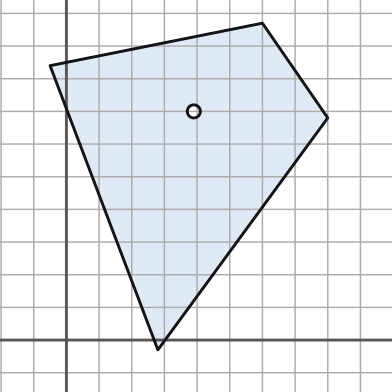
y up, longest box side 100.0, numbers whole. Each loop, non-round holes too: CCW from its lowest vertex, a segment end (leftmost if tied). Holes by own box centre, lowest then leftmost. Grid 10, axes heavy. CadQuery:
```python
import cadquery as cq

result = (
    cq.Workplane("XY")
    .moveTo(28.0, -3.0)
    .lineTo(80.0, 68.0)
    .lineTo(60.0, 97.0)
    .lineTo(-5.0, 84.0)
    .close()
    .moveTo(39.0, 70.0)
    .circle(2.0)
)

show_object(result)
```